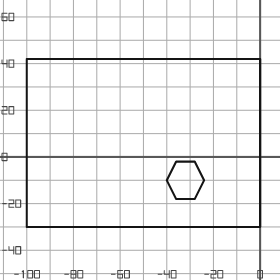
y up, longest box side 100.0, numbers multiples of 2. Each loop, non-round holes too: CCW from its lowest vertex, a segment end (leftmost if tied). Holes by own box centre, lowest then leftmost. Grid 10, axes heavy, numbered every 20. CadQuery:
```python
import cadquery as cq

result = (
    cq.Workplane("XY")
    .moveTo(-100.0, -30.0)
    .lineTo(0.0, -30.0)
    .lineTo(0.0, 42.0)
    .lineTo(-100.0, 42.0)
    .close()
    .moveTo(-36.0, -18.0)
    .lineTo(-28.0, -18.0)
    .lineTo(-24.0, -10.0)
    .lineTo(-28.0, -2.0)
    .lineTo(-36.0, -2.0)
    .lineTo(-40.0, -10.0)
    .close()
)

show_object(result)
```